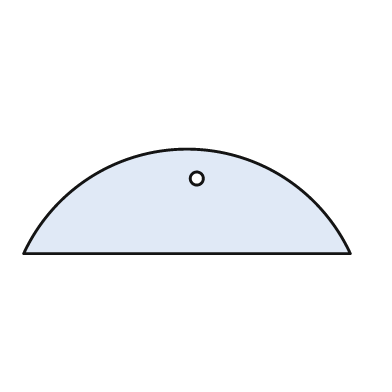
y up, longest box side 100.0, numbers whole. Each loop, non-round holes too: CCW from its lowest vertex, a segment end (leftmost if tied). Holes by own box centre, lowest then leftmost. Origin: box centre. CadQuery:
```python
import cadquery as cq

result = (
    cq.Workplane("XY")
    .moveTo(-50.0, -16.0)
    .lineTo(50.0, -16.0)
    .threePointArc((0.0, 16.0), (-50.0, -16.0))
    .close()
    .moveTo(3.0, 7.0)
    .circle(2.0)
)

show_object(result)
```